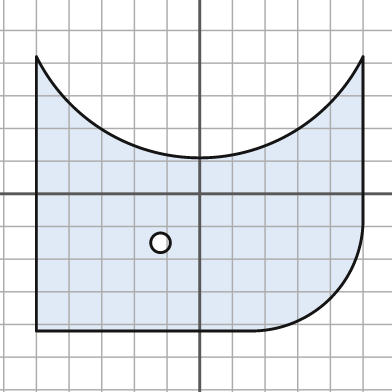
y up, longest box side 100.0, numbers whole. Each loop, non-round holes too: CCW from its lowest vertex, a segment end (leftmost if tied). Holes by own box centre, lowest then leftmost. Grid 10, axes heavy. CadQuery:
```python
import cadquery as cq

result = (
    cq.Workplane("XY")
    .moveTo(-50.0, -42.0)
    .lineTo(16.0, -42.0)
    .threePointArc((40.0, -32.0), (50.0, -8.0))
    .lineTo(50.0, 42.0)
    .threePointArc((0.0, 11.0), (-50.0, 42.0))
    .close()
    .moveTo(-12.0, -15.0)
    .circle(3.0)
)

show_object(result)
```